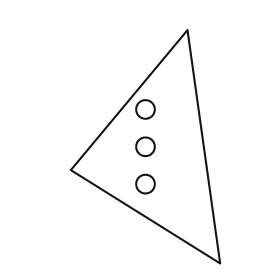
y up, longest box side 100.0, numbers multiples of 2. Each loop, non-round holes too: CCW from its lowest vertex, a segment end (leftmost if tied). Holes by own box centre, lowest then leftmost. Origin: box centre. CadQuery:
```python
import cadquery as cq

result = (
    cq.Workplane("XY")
    .moveTo(32.0, -50.0)
    .lineTo(18.0, 50.0)
    .lineTo(-32.0, -10.0)
    .close()
    .moveTo(0.0, -16.0)
    .circle(4.0)
    .moveTo(0.0, 0.0)
    .circle(4.0)
    .moveTo(0.0, 16.0)
    .circle(4.0)
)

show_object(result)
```